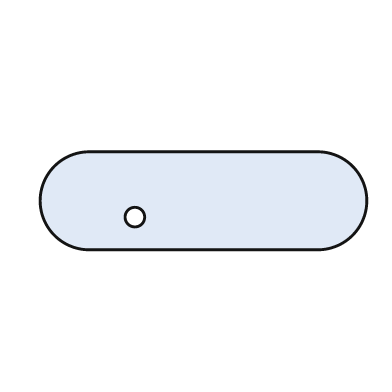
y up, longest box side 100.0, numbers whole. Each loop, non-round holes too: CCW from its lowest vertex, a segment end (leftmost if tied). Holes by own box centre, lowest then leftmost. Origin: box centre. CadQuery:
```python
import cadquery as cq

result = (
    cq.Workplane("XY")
    .moveTo(-35.0, -15.0)
    .lineTo(35.0, -15.0)
    .threePointArc((50.0, 0.0), (35.0, 15.0))
    .lineTo(-35.0, 15.0)
    .threePointArc((-50.0, 0.0), (-35.0, -15.0))
    .close()
    .moveTo(-21.0, -5.0)
    .circle(3.0)
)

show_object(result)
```